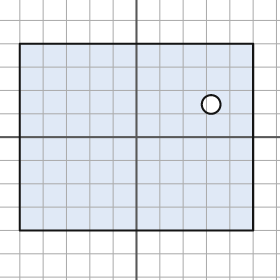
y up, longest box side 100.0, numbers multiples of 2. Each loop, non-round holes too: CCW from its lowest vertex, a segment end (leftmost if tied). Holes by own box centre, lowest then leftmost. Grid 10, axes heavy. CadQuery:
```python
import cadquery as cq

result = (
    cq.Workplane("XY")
    .moveTo(-50.0, -40.0)
    .lineTo(50.0, -40.0)
    .lineTo(50.0, 40.0)
    .lineTo(-50.0, 40.0)
    .close()
    .moveTo(32.0, 14.0)
    .circle(4.0)
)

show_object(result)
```